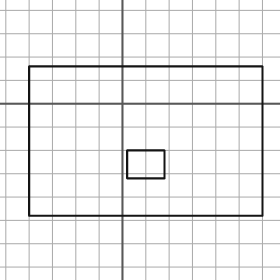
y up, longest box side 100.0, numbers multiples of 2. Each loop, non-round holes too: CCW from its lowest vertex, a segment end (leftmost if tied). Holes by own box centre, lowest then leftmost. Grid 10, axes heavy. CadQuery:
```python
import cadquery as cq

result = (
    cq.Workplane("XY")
    .moveTo(-40.0, -48.0)
    .lineTo(60.0, -48.0)
    .lineTo(60.0, 16.0)
    .lineTo(-40.0, 16.0)
    .close()
    .moveTo(2.0, -32.0)
    .lineTo(18.0, -32.0)
    .lineTo(18.0, -20.0)
    .lineTo(2.0, -20.0)
    .close()
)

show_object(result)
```